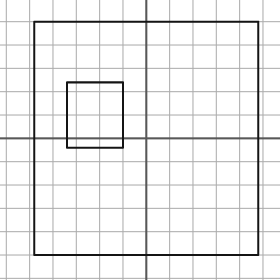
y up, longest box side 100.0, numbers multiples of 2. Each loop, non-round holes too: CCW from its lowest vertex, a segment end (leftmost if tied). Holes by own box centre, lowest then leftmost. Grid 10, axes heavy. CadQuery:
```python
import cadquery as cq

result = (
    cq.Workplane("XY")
    .moveTo(-48.0, -50.0)
    .lineTo(48.0, -50.0)
    .lineTo(48.0, 50.0)
    .lineTo(-48.0, 50.0)
    .close()
    .moveTo(-34.0, -4.0)
    .lineTo(-10.0, -4.0)
    .lineTo(-10.0, 24.0)
    .lineTo(-34.0, 24.0)
    .close()
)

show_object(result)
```